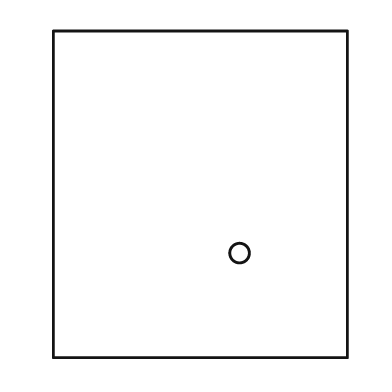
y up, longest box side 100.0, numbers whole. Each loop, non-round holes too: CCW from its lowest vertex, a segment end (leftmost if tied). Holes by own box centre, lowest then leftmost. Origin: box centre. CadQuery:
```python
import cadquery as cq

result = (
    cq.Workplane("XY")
    .moveTo(-45.0, -50.0)
    .lineTo(45.0, -50.0)
    .lineTo(45.0, 50.0)
    .lineTo(-45.0, 50.0)
    .close()
    .moveTo(12.0, -18.0)
    .circle(3.0)
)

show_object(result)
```